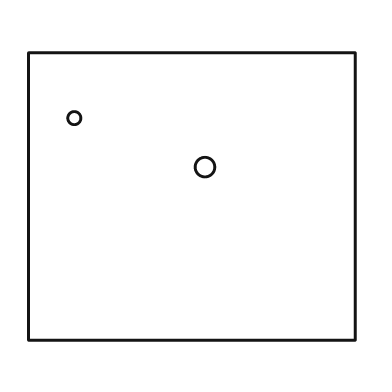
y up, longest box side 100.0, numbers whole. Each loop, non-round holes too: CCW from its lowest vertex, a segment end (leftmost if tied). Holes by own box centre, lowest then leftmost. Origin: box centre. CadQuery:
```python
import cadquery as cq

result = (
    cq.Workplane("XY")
    .moveTo(-50.0, -44.0)
    .lineTo(50.0, -44.0)
    .lineTo(50.0, 44.0)
    .lineTo(-50.0, 44.0)
    .close()
    .moveTo(4.0, 9.0)
    .circle(3.0)
    .moveTo(-36.0, 24.0)
    .circle(2.0)
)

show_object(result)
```